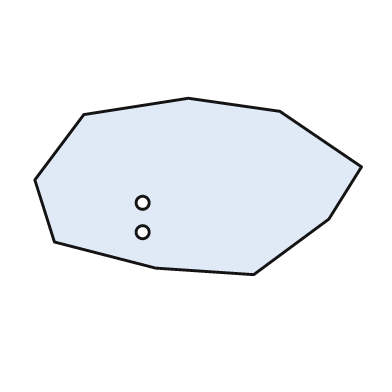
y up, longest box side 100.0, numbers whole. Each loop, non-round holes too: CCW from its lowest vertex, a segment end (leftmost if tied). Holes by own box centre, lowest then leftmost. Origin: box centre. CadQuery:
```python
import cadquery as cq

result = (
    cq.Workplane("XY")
    .moveTo(17.0, -27.0)
    .lineTo(40.0, -10.0)
    .lineTo(50.0, 6.0)
    .lineTo(25.0, 23.0)
    .lineTo(-3.0, 27.0)
    .lineTo(-35.0, 22.0)
    .lineTo(-50.0, 2.0)
    .lineTo(-44.0, -17.0)
    .lineTo(-13.0, -25.0)
    .close()
    .moveTo(-17.0, -14.0)
    .circle(2.0)
    .moveTo(-17.0, -5.0)
    .circle(2.0)
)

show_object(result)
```